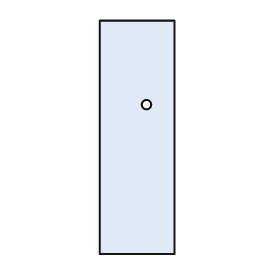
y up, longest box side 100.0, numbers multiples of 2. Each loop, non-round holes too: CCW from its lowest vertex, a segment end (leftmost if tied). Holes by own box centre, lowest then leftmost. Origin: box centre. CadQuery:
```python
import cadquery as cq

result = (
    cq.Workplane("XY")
    .moveTo(-16.0, -50.0)
    .lineTo(16.0, -50.0)
    .lineTo(16.0, 50.0)
    .lineTo(-16.0, 50.0)
    .close()
    .moveTo(4.0, 14.0)
    .circle(2.0)
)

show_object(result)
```